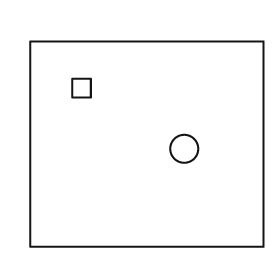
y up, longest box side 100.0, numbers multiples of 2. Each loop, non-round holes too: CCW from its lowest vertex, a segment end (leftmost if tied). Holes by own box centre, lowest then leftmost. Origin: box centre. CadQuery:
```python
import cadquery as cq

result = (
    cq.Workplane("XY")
    .moveTo(-50.0, -44.0)
    .lineTo(50.0, -44.0)
    .lineTo(50.0, 44.0)
    .lineTo(-50.0, 44.0)
    .close()
    .moveTo(16.0, -2.0)
    .circle(6.0)
    .moveTo(-32.0, 20.0)
    .lineTo(-24.0, 20.0)
    .lineTo(-24.0, 28.0)
    .lineTo(-32.0, 28.0)
    .close()
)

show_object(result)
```